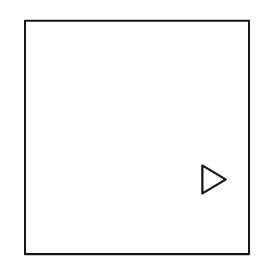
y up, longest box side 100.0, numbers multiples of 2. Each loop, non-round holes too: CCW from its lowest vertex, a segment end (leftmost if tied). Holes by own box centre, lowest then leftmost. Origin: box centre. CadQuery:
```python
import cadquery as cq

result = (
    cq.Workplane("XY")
    .moveTo(-48.0, -50.0)
    .lineTo(48.0, -50.0)
    .lineTo(48.0, 50.0)
    .lineTo(-48.0, 50.0)
    .close()
    .moveTo(28.0, -24.0)
    .lineTo(38.0, -18.0)
    .lineTo(28.0, -12.0)
    .close()
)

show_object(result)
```